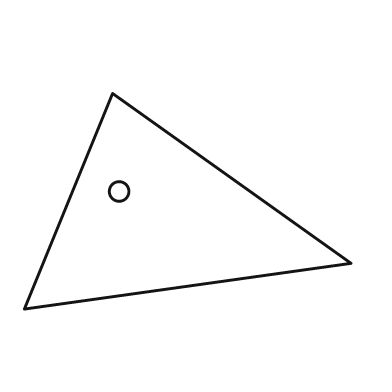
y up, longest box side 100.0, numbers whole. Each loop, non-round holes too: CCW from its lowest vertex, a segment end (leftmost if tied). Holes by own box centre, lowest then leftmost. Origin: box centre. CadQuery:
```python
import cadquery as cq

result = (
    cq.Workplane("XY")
    .moveTo(-50.0, -33.0)
    .lineTo(50.0, -19.0)
    .lineTo(-23.0, 33.0)
    .close()
    .moveTo(-21.0, 3.0)
    .circle(3.0)
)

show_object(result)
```